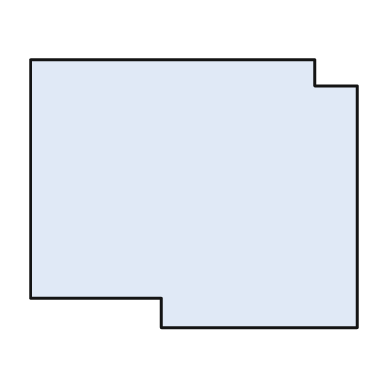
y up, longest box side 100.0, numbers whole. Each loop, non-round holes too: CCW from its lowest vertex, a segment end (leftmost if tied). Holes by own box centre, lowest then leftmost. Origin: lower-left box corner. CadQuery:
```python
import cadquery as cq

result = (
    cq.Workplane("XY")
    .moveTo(40.0, 0.0)
    .lineTo(100.0, 0.0)
    .lineTo(100.0, 74.0)
    .lineTo(87.0, 74.0)
    .lineTo(87.0, 82.0)
    .lineTo(0.0, 82.0)
    .lineTo(0.0, 9.0)
    .lineTo(40.0, 9.0)
    .close()
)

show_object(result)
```